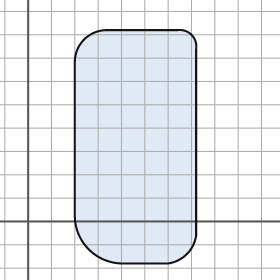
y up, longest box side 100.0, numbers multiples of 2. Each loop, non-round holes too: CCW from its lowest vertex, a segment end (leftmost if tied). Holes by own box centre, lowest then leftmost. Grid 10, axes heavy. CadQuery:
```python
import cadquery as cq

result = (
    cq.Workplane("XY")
    .moveTo(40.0, -18.0)
    .lineTo(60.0, -18.0)
    .threePointArc((68.0, -14.0), (72.0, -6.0))
    .lineTo(72.0, 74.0)
    .threePointArc((70.0, 80.0), (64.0, 82.0))
    .lineTo(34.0, 82.0)
    .threePointArc((24.0, 78.0), (20.0, 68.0))
    .lineTo(20.0, 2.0)
    .threePointArc((26.0, -12.0), (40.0, -18.0))
    .close()
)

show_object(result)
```